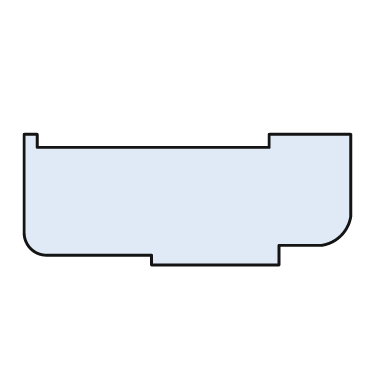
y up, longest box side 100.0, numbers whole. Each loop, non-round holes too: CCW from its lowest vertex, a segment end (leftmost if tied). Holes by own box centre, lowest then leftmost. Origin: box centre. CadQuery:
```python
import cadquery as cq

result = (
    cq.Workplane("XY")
    .moveTo(-11.0, -20.0)
    .lineTo(28.0, -20.0)
    .lineTo(28.0, -14.0)
    .lineTo(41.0, -14.0)
    .threePointArc((47.0, -11.0), (50.0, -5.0))
    .lineTo(50.0, 20.0)
    .lineTo(25.0, 20.0)
    .lineTo(25.0, 16.0)
    .lineTo(-46.0, 16.0)
    .lineTo(-46.0, 20.0)
    .lineTo(-50.0, 20.0)
    .lineTo(-50.0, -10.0)
    .threePointArc((-48.0, -15.0), (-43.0, -17.0))
    .lineTo(-11.0, -17.0)
    .close()
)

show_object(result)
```